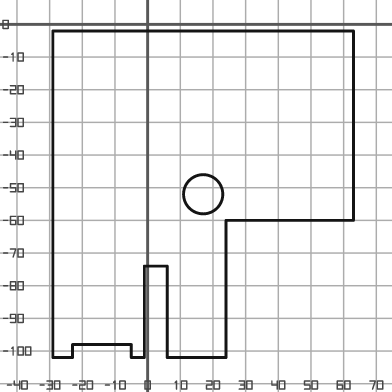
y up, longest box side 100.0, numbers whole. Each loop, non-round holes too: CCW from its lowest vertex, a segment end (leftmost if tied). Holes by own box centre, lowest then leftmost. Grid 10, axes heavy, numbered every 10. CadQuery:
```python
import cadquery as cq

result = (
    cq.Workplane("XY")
    .moveTo(-29.0, -102.0)
    .lineTo(-23.0, -102.0)
    .lineTo(-23.0, -98.0)
    .lineTo(-5.0, -98.0)
    .lineTo(-5.0, -102.0)
    .lineTo(-1.0, -102.0)
    .lineTo(-1.0, -74.0)
    .lineTo(6.0, -74.0)
    .lineTo(6.0, -102.0)
    .lineTo(24.0, -102.0)
    .lineTo(24.0, -60.0)
    .lineTo(63.0, -60.0)
    .lineTo(63.0, -2.0)
    .lineTo(-29.0, -2.0)
    .close()
    .moveTo(17.0, -52.0)
    .circle(6.0)
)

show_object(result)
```